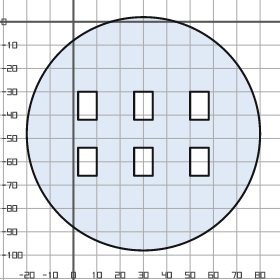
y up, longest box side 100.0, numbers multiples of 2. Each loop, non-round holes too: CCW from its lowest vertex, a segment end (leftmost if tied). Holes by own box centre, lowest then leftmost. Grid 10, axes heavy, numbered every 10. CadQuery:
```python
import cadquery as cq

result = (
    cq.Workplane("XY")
    .moveTo(30.0, -48.0)
    .circle(50.0)
    .moveTo(2.0, -66.0)
    .lineTo(10.0, -66.0)
    .lineTo(10.0, -54.0)
    .lineTo(2.0, -54.0)
    .close()
    .moveTo(26.0, -66.0)
    .lineTo(34.0, -66.0)
    .lineTo(34.0, -54.0)
    .lineTo(26.0, -54.0)
    .close()
    .moveTo(50.0, -66.0)
    .lineTo(58.0, -66.0)
    .lineTo(58.0, -54.0)
    .lineTo(50.0, -54.0)
    .close()
    .moveTo(2.0, -42.0)
    .lineTo(10.0, -42.0)
    .lineTo(10.0, -30.0)
    .lineTo(2.0, -30.0)
    .close()
    .moveTo(26.0, -42.0)
    .lineTo(34.0, -42.0)
    .lineTo(34.0, -30.0)
    .lineTo(26.0, -30.0)
    .close()
    .moveTo(50.0, -42.0)
    .lineTo(58.0, -42.0)
    .lineTo(58.0, -30.0)
    .lineTo(50.0, -30.0)
    .close()
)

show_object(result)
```